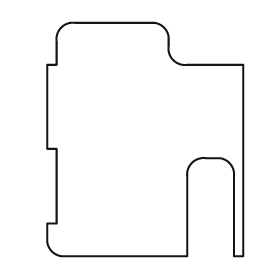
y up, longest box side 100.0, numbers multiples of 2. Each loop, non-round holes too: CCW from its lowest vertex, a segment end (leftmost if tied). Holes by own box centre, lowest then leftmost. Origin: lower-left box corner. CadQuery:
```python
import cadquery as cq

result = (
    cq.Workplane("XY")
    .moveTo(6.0, 0.0)
    .lineTo(60.0, 0.0)
    .lineTo(60.0, 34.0)
    .threePointArc((62.0, 40.0), (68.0, 42.0))
    .lineTo(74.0, 42.0)
    .threePointArc((78.0, 40.0), (80.0, 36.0))
    .lineTo(80.0, 0.0)
    .lineTo(84.0, 0.0)
    .lineTo(84.0, 82.0)
    .lineTo(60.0, 82.0)
    .threePointArc((54.0, 84.0), (52.0, 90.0))
    .lineTo(52.0, 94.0)
    .threePointArc((50.0, 98.0), (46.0, 100.0))
    .lineTo(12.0, 100.0)
    .threePointArc((6.0, 98.0), (4.0, 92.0))
    .lineTo(4.0, 82.0)
    .lineTo(0.0, 82.0)
    .lineTo(0.0, 46.0)
    .lineTo(4.0, 46.0)
    .lineTo(4.0, 14.0)
    .lineTo(0.0, 14.0)
    .lineTo(0.0, 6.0)
    .threePointArc((2.0, 2.0), (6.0, 0.0))
    .close()
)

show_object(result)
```